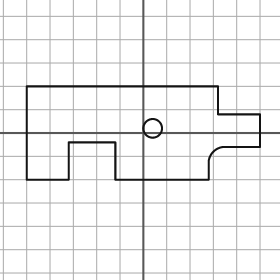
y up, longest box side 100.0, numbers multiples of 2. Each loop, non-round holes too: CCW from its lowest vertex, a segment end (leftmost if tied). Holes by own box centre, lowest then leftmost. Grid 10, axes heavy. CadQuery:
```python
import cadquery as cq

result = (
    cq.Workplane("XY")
    .moveTo(-50.0, -20.0)
    .lineTo(-32.0, -20.0)
    .lineTo(-32.0, -4.0)
    .lineTo(-12.0, -4.0)
    .lineTo(-12.0, -20.0)
    .lineTo(28.0, -20.0)
    .lineTo(28.0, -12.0)
    .threePointArc((30.0, -8.0), (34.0, -6.0))
    .lineTo(50.0, -6.0)
    .lineTo(50.0, 8.0)
    .lineTo(32.0, 8.0)
    .lineTo(32.0, 20.0)
    .lineTo(-50.0, 20.0)
    .close()
    .moveTo(4.0, 2.0)
    .circle(4.0)
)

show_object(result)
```